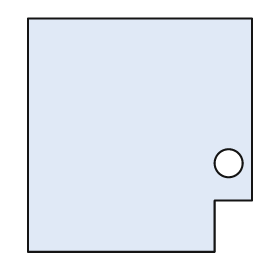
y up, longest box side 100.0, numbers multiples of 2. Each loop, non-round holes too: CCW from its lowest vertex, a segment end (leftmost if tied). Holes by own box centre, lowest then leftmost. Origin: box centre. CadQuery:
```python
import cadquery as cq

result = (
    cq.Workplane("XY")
    .moveTo(-48.0, -50.0)
    .lineTo(32.0, -50.0)
    .lineTo(32.0, -28.0)
    .lineTo(48.0, -28.0)
    .lineTo(48.0, 50.0)
    .lineTo(-48.0, 50.0)
    .close()
    .moveTo(38.0, -12.0)
    .circle(6.0)
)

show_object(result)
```